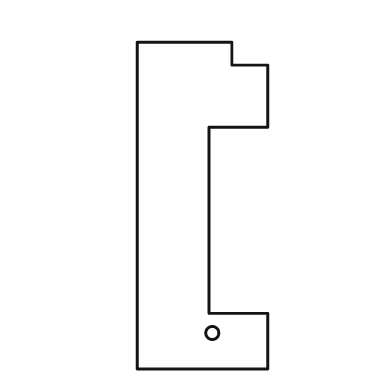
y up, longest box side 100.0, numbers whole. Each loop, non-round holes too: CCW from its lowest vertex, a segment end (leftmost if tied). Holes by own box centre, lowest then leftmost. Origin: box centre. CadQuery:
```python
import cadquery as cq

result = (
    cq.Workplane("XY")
    .moveTo(-20.0, -50.0)
    .lineTo(20.0, -50.0)
    .lineTo(20.0, -33.0)
    .lineTo(2.0, -33.0)
    .lineTo(2.0, 24.0)
    .lineTo(20.0, 24.0)
    .lineTo(20.0, 43.0)
    .lineTo(9.0, 43.0)
    .lineTo(9.0, 50.0)
    .lineTo(-20.0, 50.0)
    .close()
    .moveTo(3.0, -39.0)
    .circle(2.0)
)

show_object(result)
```